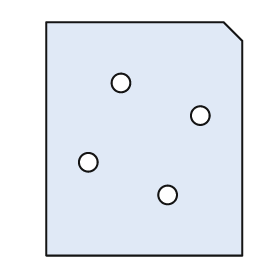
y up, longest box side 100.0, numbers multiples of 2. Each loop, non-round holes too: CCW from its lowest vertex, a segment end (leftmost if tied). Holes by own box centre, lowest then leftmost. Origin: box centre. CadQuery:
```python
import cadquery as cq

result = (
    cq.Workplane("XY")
    .moveTo(-42.0, -50.0)
    .lineTo(42.0, -50.0)
    .lineTo(42.0, 42.0)
    .lineTo(34.0, 50.0)
    .lineTo(-42.0, 50.0)
    .close()
    .moveTo(10.0, -24.0)
    .circle(4.0)
    .moveTo(-24.0, -10.0)
    .circle(4.0)
    .moveTo(24.0, 10.0)
    .circle(4.0)
    .moveTo(-10.0, 24.0)
    .circle(4.0)
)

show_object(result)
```